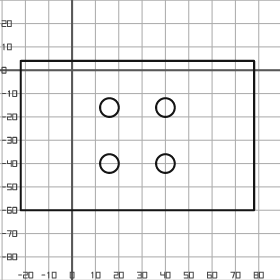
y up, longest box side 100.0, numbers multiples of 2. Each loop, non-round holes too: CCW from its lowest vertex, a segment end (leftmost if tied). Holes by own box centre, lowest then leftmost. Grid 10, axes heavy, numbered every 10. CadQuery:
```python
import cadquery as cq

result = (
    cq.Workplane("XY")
    .moveTo(-22.0, -60.0)
    .lineTo(78.0, -60.0)
    .lineTo(78.0, 4.0)
    .lineTo(-22.0, 4.0)
    .close()
    .moveTo(16.0, -40.0)
    .circle(4.0)
    .moveTo(40.0, -40.0)
    .circle(4.0)
    .moveTo(16.0, -16.0)
    .circle(4.0)
    .moveTo(40.0, -16.0)
    .circle(4.0)
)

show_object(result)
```